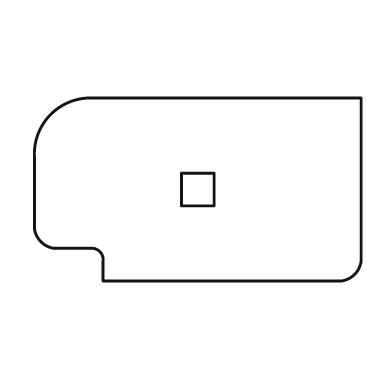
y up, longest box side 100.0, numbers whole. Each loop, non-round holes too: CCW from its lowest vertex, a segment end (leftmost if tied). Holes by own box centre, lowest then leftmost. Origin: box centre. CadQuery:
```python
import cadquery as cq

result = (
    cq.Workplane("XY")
    .moveTo(-29.0, -28.0)
    .lineTo(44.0, -28.0)
    .threePointArc((48.0, -26.0), (50.0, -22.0))
    .lineTo(50.0, 28.0)
    .lineTo(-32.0, 28.0)
    .threePointArc((-45.0, 23.0), (-50.0, 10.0))
    .lineTo(-50.0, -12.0)
    .threePointArc((-48.0, -16.0), (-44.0, -18.0))
    .lineTo(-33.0, -18.0)
    .threePointArc((-30.0, -19.0), (-29.0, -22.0))
    .close()
    .moveTo(-5.0, -5.0)
    .lineTo(5.0, -5.0)
    .lineTo(5.0, 5.0)
    .lineTo(-5.0, 5.0)
    .close()
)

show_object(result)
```